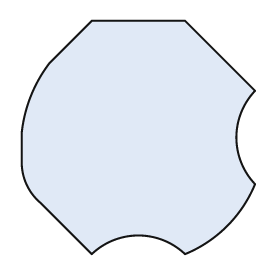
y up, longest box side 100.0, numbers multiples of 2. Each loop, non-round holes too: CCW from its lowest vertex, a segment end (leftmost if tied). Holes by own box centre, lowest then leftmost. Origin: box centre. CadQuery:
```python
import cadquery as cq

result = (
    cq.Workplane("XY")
    .moveTo(-20.0, -50.0)
    .threePointArc((0.0, -42.0), (20.0, -50.0))
    .threePointArc((38.0, -38.0), (50.0, -20.0))
    .threePointArc((42.0, 0.0), (50.0, 20.0))
    .lineTo(20.0, 50.0)
    .lineTo(-20.0, 50.0)
    .lineTo(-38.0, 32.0)
    .threePointArc((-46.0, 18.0), (-50.0, 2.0))
    .lineTo(-50.0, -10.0)
    .threePointArc((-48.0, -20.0), (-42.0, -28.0))
    .close()
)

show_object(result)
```